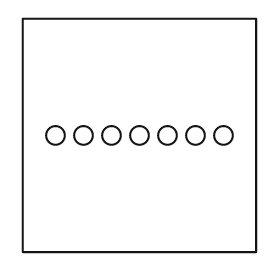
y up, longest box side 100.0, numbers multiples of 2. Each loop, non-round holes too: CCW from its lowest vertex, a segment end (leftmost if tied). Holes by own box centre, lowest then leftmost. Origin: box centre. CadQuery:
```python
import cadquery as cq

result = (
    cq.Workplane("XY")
    .moveTo(-50.0, -50.0)
    .lineTo(50.0, -50.0)
    .lineTo(50.0, 50.0)
    .lineTo(-50.0, 50.0)
    .close()
    .moveTo(-36.0, 0.0)
    .circle(4.0)
    .moveTo(-24.0, 0.0)
    .circle(4.0)
    .moveTo(-12.0, 0.0)
    .circle(4.0)
    .moveTo(0.0, 0.0)
    .circle(4.0)
    .moveTo(12.0, 0.0)
    .circle(4.0)
    .moveTo(24.0, 0.0)
    .circle(4.0)
    .moveTo(36.0, 0.0)
    .circle(4.0)
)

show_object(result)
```